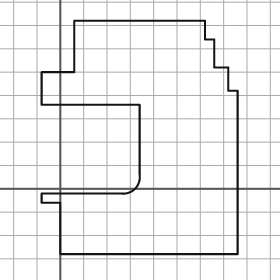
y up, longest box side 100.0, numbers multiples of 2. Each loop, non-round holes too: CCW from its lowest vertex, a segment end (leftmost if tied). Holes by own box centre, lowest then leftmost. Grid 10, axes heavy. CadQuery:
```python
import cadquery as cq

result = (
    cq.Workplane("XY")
    .moveTo(0.0, -28.0)
    .lineTo(76.0, -28.0)
    .lineTo(76.0, 42.0)
    .lineTo(72.0, 42.0)
    .lineTo(72.0, 52.0)
    .lineTo(66.0, 52.0)
    .lineTo(66.0, 64.0)
    .lineTo(62.0, 64.0)
    .lineTo(62.0, 72.0)
    .lineTo(6.0, 72.0)
    .lineTo(6.0, 50.0)
    .lineTo(-8.0, 50.0)
    .lineTo(-8.0, 36.0)
    .lineTo(34.0, 36.0)
    .lineTo(34.0, 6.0)
    .threePointArc((32.0, 0.0), (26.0, -2.0))
    .lineTo(-8.0, -2.0)
    .lineTo(-8.0, -6.0)
    .lineTo(0.0, -6.0)
    .close()
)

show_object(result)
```